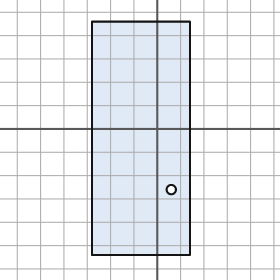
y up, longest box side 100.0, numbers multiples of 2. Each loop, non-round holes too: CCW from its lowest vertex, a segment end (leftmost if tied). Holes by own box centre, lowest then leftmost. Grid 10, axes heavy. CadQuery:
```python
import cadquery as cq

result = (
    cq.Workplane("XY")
    .moveTo(-28.0, -54.0)
    .lineTo(14.0, -54.0)
    .lineTo(14.0, 46.0)
    .lineTo(-28.0, 46.0)
    .close()
    .moveTo(6.0, -26.0)
    .circle(2.0)
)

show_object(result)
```